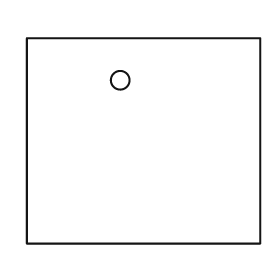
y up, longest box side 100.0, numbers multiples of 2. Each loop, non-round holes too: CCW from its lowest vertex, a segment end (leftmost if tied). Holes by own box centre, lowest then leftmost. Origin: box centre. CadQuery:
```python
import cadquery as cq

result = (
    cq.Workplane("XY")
    .moveTo(-50.0, -44.0)
    .lineTo(50.0, -44.0)
    .lineTo(50.0, 44.0)
    .lineTo(-50.0, 44.0)
    .close()
    .moveTo(-10.0, 26.0)
    .circle(4.0)
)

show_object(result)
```